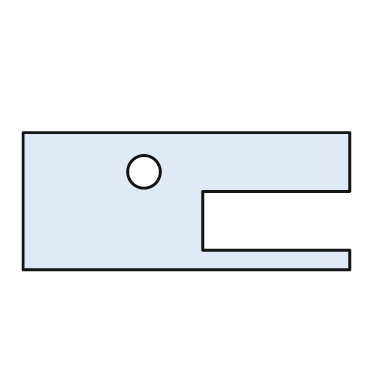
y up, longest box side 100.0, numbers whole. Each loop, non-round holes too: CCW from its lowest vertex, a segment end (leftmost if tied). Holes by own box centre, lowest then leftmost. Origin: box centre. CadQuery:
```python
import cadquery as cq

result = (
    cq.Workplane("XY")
    .moveTo(-50.0, -21.0)
    .lineTo(50.0, -21.0)
    .lineTo(50.0, -15.0)
    .lineTo(5.0, -15.0)
    .lineTo(5.0, 3.0)
    .lineTo(50.0, 3.0)
    .lineTo(50.0, 21.0)
    .lineTo(-50.0, 21.0)
    .close()
    .moveTo(-13.0, 9.0)
    .circle(5.0)
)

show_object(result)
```